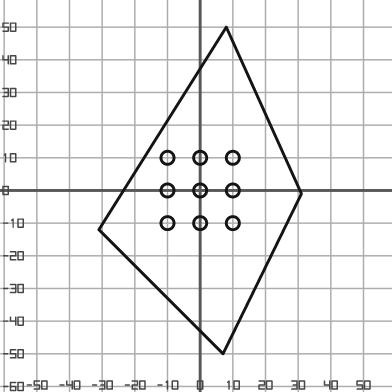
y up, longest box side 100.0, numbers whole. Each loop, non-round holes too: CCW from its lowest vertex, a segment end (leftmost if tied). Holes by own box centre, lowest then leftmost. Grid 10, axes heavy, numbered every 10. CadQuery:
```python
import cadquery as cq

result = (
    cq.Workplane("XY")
    .moveTo(7.0, -50.0)
    .lineTo(31.0, -1.0)
    .lineTo(8.0, 50.0)
    .lineTo(-31.0, -12.0)
    .close()
    .moveTo(-10.0, -10.0)
    .circle(2.0)
    .moveTo(0.0, -10.0)
    .circle(2.0)
    .moveTo(10.0, -10.0)
    .circle(2.0)
    .moveTo(-10.0, 0.0)
    .circle(2.0)
    .moveTo(0.0, 0.0)
    .circle(2.0)
    .moveTo(10.0, 0.0)
    .circle(2.0)
    .moveTo(-10.0, 10.0)
    .circle(2.0)
    .moveTo(0.0, 10.0)
    .circle(2.0)
    .moveTo(10.0, 10.0)
    .circle(2.0)
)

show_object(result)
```